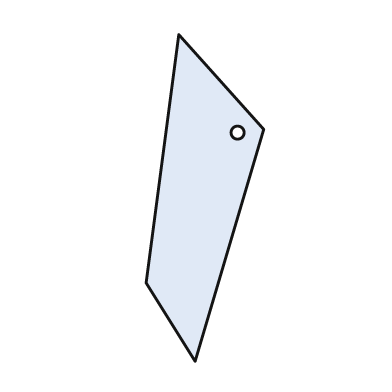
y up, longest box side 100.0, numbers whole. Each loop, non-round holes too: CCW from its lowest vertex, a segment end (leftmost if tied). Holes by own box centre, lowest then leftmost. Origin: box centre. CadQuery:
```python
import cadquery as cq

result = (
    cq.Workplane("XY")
    .moveTo(-3.0, -50.0)
    .lineTo(18.0, 21.0)
    .lineTo(-8.0, 50.0)
    .lineTo(-18.0, -26.0)
    .close()
    .moveTo(10.0, 20.0)
    .circle(2.0)
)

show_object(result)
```